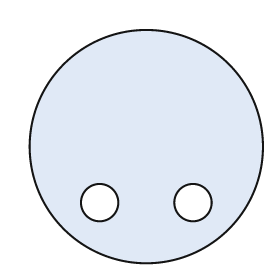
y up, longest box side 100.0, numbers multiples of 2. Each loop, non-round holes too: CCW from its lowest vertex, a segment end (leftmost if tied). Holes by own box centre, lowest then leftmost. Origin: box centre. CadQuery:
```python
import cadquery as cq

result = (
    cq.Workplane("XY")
    .moveTo(0.0, 0.0)
    .circle(50.0)
    .moveTo(-20.0, -24.0)
    .circle(8.0)
    .moveTo(20.0, -24.0)
    .circle(8.0)
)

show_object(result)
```